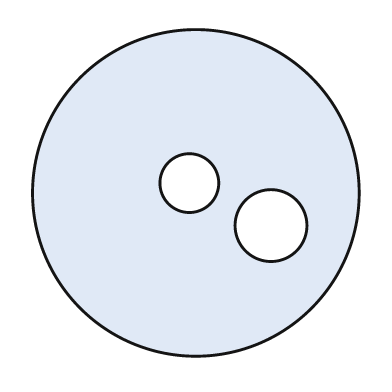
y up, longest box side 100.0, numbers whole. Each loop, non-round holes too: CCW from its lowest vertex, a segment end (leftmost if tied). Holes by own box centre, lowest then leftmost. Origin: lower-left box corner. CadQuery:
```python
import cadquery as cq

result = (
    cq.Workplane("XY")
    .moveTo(50.0, 50.0)
    .circle(50.0)
    .moveTo(73.0, 40.0)
    .circle(11.0)
    .moveTo(48.0, 53.0)
    .circle(9.0)
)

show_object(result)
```